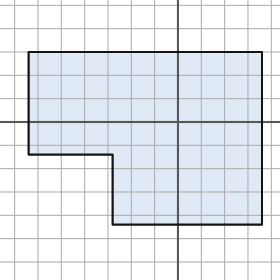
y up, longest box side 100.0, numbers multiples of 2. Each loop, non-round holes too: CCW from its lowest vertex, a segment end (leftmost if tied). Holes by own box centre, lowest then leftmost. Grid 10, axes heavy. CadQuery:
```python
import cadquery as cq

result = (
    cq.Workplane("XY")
    .moveTo(-28.0, -44.0)
    .lineTo(36.0, -44.0)
    .lineTo(36.0, 30.0)
    .lineTo(-64.0, 30.0)
    .lineTo(-64.0, -14.0)
    .lineTo(-28.0, -14.0)
    .close()
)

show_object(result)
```